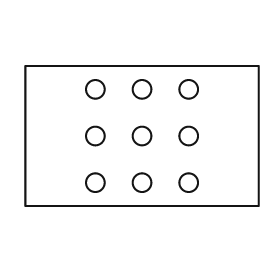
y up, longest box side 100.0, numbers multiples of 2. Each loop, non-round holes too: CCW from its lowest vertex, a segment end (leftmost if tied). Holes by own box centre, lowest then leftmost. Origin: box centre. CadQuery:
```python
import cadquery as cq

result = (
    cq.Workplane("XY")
    .moveTo(-50.0, -30.0)
    .lineTo(50.0, -30.0)
    .lineTo(50.0, 30.0)
    .lineTo(-50.0, 30.0)
    .close()
    .moveTo(-20.0, -20.0)
    .circle(4.0)
    .moveTo(0.0, -20.0)
    .circle(4.0)
    .moveTo(20.0, -20.0)
    .circle(4.0)
    .moveTo(-20.0, 0.0)
    .circle(4.0)
    .moveTo(0.0, 0.0)
    .circle(4.0)
    .moveTo(20.0, 0.0)
    .circle(4.0)
    .moveTo(-20.0, 20.0)
    .circle(4.0)
    .moveTo(0.0, 20.0)
    .circle(4.0)
    .moveTo(20.0, 20.0)
    .circle(4.0)
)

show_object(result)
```